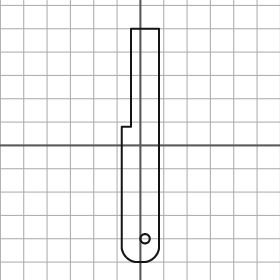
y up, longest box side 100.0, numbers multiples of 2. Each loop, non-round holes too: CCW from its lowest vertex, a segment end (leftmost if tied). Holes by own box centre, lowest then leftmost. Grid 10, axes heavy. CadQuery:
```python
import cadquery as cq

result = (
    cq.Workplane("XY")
    .moveTo(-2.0, -50.0)
    .lineTo(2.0, -50.0)
    .threePointArc((6.0, -48.0), (8.0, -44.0))
    .lineTo(8.0, 50.0)
    .lineTo(-4.0, 50.0)
    .lineTo(-4.0, 8.0)
    .lineTo(-8.0, 8.0)
    .lineTo(-8.0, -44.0)
    .threePointArc((-6.0, -48.0), (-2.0, -50.0))
    .close()
    .moveTo(2.0, -40.0)
    .circle(2.0)
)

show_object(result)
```